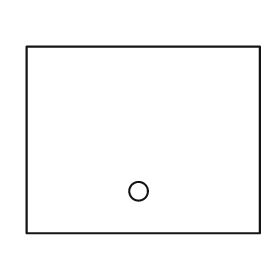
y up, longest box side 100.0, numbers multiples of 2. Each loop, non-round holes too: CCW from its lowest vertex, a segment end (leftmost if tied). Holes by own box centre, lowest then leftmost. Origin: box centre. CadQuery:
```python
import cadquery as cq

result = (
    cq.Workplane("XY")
    .moveTo(-50.0, -40.0)
    .lineTo(50.0, -40.0)
    .lineTo(50.0, 40.0)
    .lineTo(-50.0, 40.0)
    .close()
    .moveTo(-2.0, -22.0)
    .circle(4.0)
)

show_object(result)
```